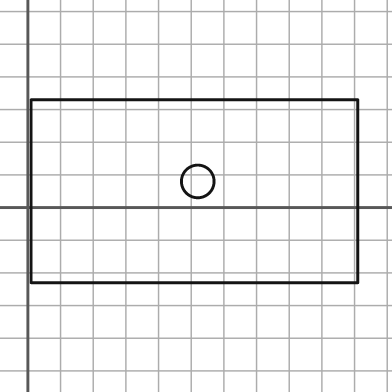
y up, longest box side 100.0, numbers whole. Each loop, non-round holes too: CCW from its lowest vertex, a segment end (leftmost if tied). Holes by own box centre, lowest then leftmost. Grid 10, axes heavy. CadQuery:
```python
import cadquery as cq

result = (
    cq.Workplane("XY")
    .moveTo(1.0, -23.0)
    .lineTo(101.0, -23.0)
    .lineTo(101.0, 33.0)
    .lineTo(1.0, 33.0)
    .close()
    .moveTo(52.0, 8.0)
    .circle(5.0)
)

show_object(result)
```